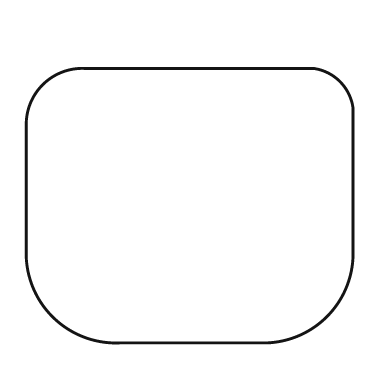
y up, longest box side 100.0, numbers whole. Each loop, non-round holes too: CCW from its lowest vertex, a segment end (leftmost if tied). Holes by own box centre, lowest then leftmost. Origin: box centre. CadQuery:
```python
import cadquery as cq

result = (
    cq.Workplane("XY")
    .moveTo(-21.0, -42.0)
    .lineTo(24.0, -42.0)
    .threePointArc((42.0, -34.0), (50.0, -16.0))
    .lineTo(50.0, 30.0)
    .threePointArc((46.0, 38.0), (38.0, 42.0))
    .lineTo(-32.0, 42.0)
    .threePointArc((-45.0, 37.0), (-50.0, 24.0))
    .lineTo(-50.0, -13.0)
    .threePointArc((-42.0, -34.0), (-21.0, -42.0))
    .close()
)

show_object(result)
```